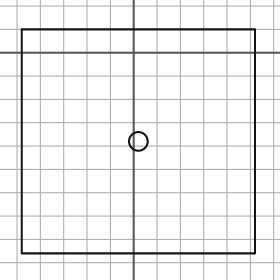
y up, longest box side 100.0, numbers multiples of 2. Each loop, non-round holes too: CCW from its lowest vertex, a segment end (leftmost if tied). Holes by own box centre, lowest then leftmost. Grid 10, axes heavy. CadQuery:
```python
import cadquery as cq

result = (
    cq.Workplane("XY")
    .moveTo(-48.0, -86.0)
    .lineTo(52.0, -86.0)
    .lineTo(52.0, 10.0)
    .lineTo(-48.0, 10.0)
    .close()
    .moveTo(2.0, -38.0)
    .circle(4.0)
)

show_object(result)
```